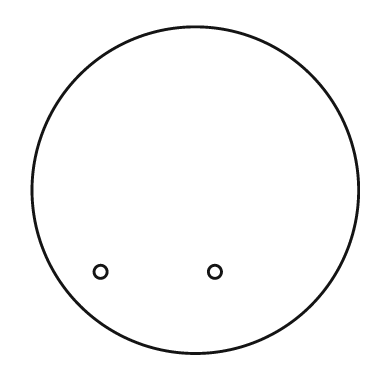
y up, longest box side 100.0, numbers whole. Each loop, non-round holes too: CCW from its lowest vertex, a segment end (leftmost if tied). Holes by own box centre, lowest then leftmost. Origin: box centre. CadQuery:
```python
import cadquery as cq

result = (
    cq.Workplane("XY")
    .moveTo(0.0, 0.0)
    .circle(50.0)
    .moveTo(-29.0, -25.0)
    .circle(2.0)
    .moveTo(6.0, -25.0)
    .circle(2.0)
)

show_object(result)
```